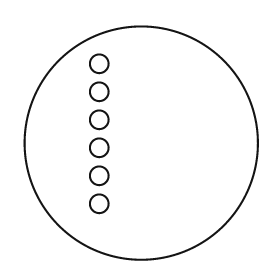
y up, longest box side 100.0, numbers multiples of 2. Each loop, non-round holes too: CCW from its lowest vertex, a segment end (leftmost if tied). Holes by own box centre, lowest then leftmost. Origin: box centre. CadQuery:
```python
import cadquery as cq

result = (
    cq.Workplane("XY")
    .moveTo(0.0, 0.0)
    .circle(50.0)
    .moveTo(-18.0, -26.0)
    .circle(4.0)
    .moveTo(-18.0, -14.0)
    .circle(4.0)
    .moveTo(-18.0, -2.0)
    .circle(4.0)
    .moveTo(-18.0, 10.0)
    .circle(4.0)
    .moveTo(-18.0, 22.0)
    .circle(4.0)
    .moveTo(-18.0, 34.0)
    .circle(4.0)
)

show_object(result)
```